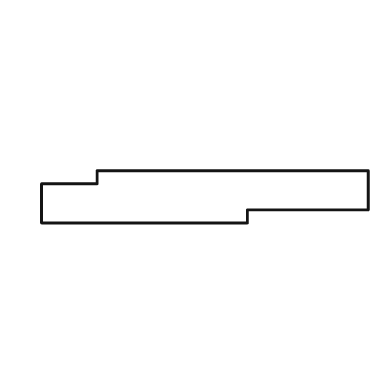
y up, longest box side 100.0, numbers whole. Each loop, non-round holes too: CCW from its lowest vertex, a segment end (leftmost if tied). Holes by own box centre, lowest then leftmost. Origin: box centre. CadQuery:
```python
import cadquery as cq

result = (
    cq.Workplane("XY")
    .moveTo(-50.0, -8.0)
    .lineTo(13.0, -8.0)
    .lineTo(13.0, -4.0)
    .lineTo(50.0, -4.0)
    .lineTo(50.0, 8.0)
    .lineTo(-33.0, 8.0)
    .lineTo(-33.0, 4.0)
    .lineTo(-50.0, 4.0)
    .close()
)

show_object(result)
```